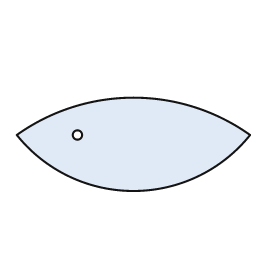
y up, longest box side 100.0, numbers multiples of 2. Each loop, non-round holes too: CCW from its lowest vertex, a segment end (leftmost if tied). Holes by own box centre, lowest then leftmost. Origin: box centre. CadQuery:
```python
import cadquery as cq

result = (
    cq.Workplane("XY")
    .moveTo(-50.0, 4.0)
    .threePointArc((0.0, -20.0), (50.0, 4.0))
    .threePointArc((0.0, 20.0), (-50.0, 4.0))
    .close()
    .moveTo(-24.0, 4.0)
    .circle(2.0)
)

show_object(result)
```